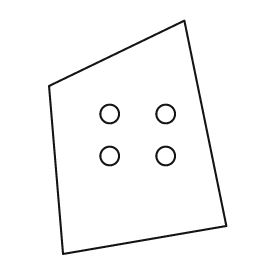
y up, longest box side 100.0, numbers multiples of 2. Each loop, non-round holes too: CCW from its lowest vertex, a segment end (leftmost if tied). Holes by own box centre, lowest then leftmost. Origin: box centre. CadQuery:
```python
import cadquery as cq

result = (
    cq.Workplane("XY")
    .moveTo(-32.0, -50.0)
    .lineTo(38.0, -38.0)
    .lineTo(20.0, 50.0)
    .lineTo(-38.0, 22.0)
    .close()
    .moveTo(-12.0, -8.0)
    .circle(4.0)
    .moveTo(12.0, -8.0)
    .circle(4.0)
    .moveTo(-12.0, 10.0)
    .circle(4.0)
    .moveTo(12.0, 10.0)
    .circle(4.0)
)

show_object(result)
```